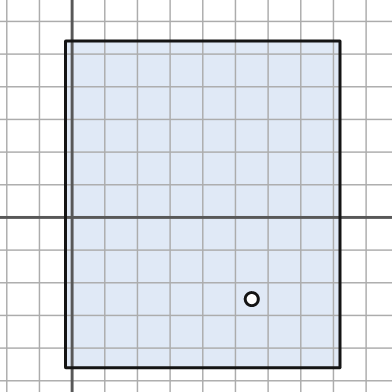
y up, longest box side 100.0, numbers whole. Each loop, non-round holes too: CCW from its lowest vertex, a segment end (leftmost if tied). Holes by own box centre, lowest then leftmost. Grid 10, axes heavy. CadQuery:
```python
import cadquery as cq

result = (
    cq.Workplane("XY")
    .moveTo(-2.0, -46.0)
    .lineTo(82.0, -46.0)
    .lineTo(82.0, 54.0)
    .lineTo(-2.0, 54.0)
    .close()
    .moveTo(55.0, -25.0)
    .circle(2.0)
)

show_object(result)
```